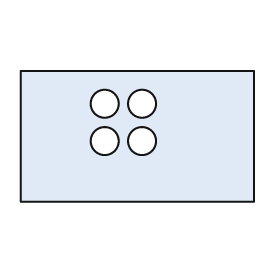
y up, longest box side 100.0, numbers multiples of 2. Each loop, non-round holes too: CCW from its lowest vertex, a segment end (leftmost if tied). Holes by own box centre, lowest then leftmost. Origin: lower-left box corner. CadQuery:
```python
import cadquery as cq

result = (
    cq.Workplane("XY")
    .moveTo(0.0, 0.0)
    .lineTo(100.0, 0.0)
    .lineTo(100.0, 56.0)
    .lineTo(0.0, 56.0)
    .close()
    .moveTo(36.0, 26.0)
    .circle(6.0)
    .moveTo(52.0, 26.0)
    .circle(6.0)
    .moveTo(36.0, 42.0)
    .circle(6.0)
    .moveTo(52.0, 42.0)
    .circle(6.0)
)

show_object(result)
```